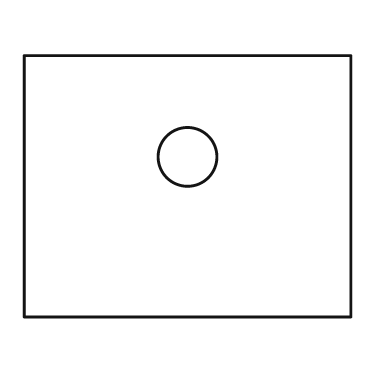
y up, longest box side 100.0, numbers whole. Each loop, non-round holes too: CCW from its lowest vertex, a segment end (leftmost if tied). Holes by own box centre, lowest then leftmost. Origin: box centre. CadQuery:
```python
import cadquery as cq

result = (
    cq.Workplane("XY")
    .moveTo(-50.0, -40.0)
    .lineTo(50.0, -40.0)
    .lineTo(50.0, 40.0)
    .lineTo(-50.0, 40.0)
    .close()
    .moveTo(0.0, 9.0)
    .circle(9.0)
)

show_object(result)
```